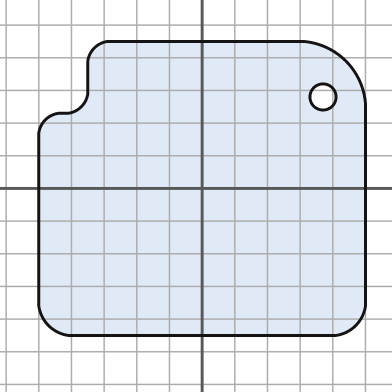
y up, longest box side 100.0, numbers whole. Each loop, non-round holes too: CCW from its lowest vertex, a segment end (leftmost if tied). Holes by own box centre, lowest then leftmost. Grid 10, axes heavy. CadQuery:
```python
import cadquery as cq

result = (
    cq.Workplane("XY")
    .moveTo(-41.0, -45.0)
    .lineTo(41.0, -45.0)
    .threePointArc((47.0, -42.0), (50.0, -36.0))
    .lineTo(50.0, 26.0)
    .threePointArc((44.0, 39.0), (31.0, 45.0))
    .lineTo(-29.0, 45.0)
    .threePointArc((-33.0, 43.0), (-35.0, 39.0))
    .lineTo(-35.0, 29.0)
    .threePointArc((-37.0, 25.0), (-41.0, 23.0))
    .lineTo(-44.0, 23.0)
    .threePointArc((-48.0, 21.0), (-50.0, 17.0))
    .lineTo(-50.0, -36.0)
    .threePointArc((-47.0, -42.0), (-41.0, -45.0))
    .close()
    .moveTo(37.0, 28.0)
    .circle(4.0)
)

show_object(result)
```